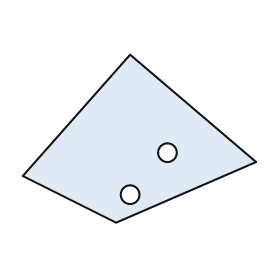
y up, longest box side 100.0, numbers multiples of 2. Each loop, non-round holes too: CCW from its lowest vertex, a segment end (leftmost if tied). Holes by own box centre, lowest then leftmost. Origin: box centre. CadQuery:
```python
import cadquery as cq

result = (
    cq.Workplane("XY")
    .moveTo(-10.0, -36.0)
    .lineTo(50.0, -10.0)
    .lineTo(-4.0, 36.0)
    .lineTo(-50.0, -16.0)
    .close()
    .moveTo(-4.0, -24.0)
    .circle(4.0)
    .moveTo(12.0, -6.0)
    .circle(4.0)
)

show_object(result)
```